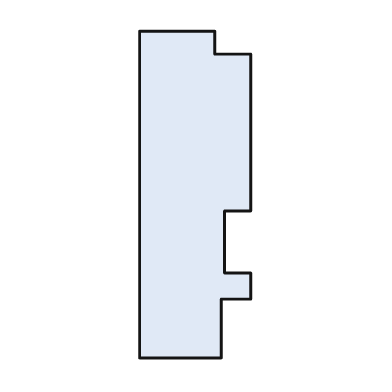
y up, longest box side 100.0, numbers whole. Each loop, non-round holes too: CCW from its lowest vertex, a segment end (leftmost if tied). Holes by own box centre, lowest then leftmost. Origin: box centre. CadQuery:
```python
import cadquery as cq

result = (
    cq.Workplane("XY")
    .moveTo(-17.0, -50.0)
    .lineTo(8.0, -50.0)
    .lineTo(8.0, -32.0)
    .lineTo(17.0, -32.0)
    .lineTo(17.0, -24.0)
    .lineTo(9.0, -24.0)
    .lineTo(9.0, -5.0)
    .lineTo(17.0, -5.0)
    .lineTo(17.0, 43.0)
    .lineTo(6.0, 43.0)
    .lineTo(6.0, 50.0)
    .lineTo(-17.0, 50.0)
    .close()
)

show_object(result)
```